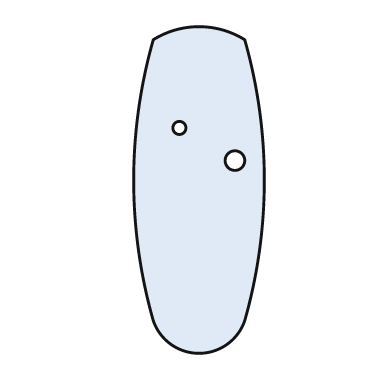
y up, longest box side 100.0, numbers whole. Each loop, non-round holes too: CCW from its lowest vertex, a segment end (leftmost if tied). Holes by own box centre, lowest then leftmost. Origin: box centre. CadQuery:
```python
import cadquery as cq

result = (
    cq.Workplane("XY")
    .moveTo(-14.0, -40.0)
    .threePointArc((0.0, -50.0), (14.0, -40.0))
    .threePointArc((20.0, 3.0), (14.0, 46.0))
    .threePointArc((0.0, 50.0), (-14.0, 46.0))
    .threePointArc((-20.0, 3.0), (-14.0, -40.0))
    .close()
    .moveTo(11.0, 9.0)
    .circle(3.0)
    .moveTo(-6.0, 19.0)
    .circle(2.0)
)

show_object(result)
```